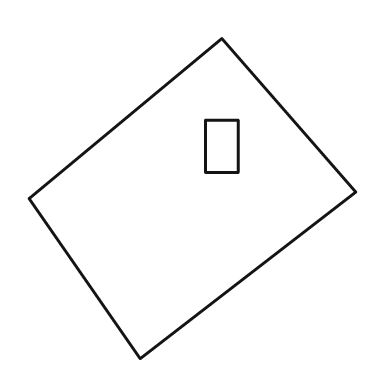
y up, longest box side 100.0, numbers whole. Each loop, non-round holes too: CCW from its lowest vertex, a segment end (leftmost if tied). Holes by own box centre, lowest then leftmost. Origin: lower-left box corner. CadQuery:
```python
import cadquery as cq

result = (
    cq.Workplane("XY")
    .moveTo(34.0, 0.0)
    .lineTo(100.0, 51.0)
    .lineTo(59.0, 98.0)
    .lineTo(0.0, 49.0)
    .close()
    .moveTo(54.0, 57.0)
    .lineTo(64.0, 57.0)
    .lineTo(64.0, 73.0)
    .lineTo(54.0, 73.0)
    .close()
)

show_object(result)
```